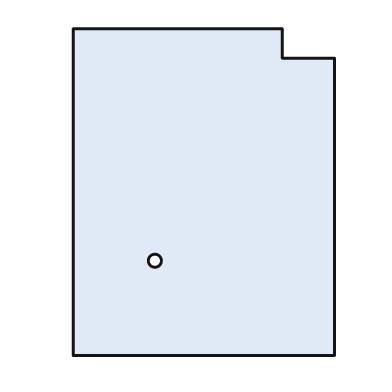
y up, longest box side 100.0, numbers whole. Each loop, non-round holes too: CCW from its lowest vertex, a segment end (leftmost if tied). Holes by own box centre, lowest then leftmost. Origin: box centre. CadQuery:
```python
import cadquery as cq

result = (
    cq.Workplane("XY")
    .moveTo(-40.0, -50.0)
    .lineTo(40.0, -50.0)
    .lineTo(40.0, 41.0)
    .lineTo(24.0, 41.0)
    .lineTo(24.0, 50.0)
    .lineTo(-40.0, 50.0)
    .close()
    .moveTo(-15.0, -21.0)
    .circle(2.0)
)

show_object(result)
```